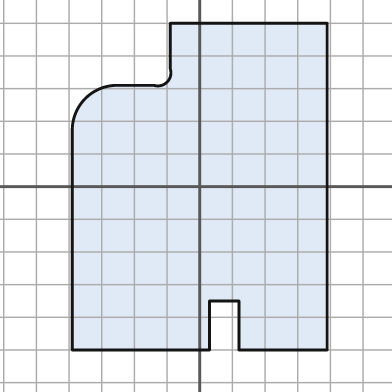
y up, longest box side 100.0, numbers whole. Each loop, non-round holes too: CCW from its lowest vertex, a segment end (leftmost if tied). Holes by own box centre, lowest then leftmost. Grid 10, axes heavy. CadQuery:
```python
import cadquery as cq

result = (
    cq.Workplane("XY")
    .moveTo(-39.0, -50.0)
    .lineTo(3.0, -50.0)
    .lineTo(3.0, -35.0)
    .lineTo(12.0, -35.0)
    .lineTo(12.0, -50.0)
    .lineTo(39.0, -50.0)
    .lineTo(39.0, 50.0)
    .lineTo(-9.0, 50.0)
    .lineTo(-9.0, 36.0)
    .threePointArc((-10.0, 32.0), (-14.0, 31.0))
    .lineTo(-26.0, 31.0)
    .threePointArc((-35.0, 27.0), (-39.0, 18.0))
    .close()
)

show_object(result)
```